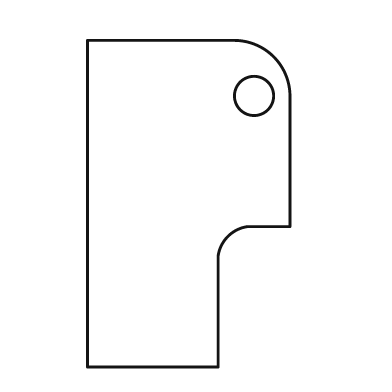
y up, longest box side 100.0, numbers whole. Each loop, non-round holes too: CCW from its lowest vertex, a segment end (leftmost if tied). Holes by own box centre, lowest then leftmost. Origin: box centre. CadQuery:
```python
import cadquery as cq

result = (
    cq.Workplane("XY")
    .moveTo(-31.0, -50.0)
    .lineTo(9.0, -50.0)
    .lineTo(9.0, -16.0)
    .threePointArc((12.0, -10.0), (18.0, -7.0))
    .lineTo(31.0, -7.0)
    .lineTo(31.0, 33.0)
    .threePointArc((26.0, 45.0), (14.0, 50.0))
    .lineTo(-31.0, 50.0)
    .close()
    .moveTo(20.0, 33.0)
    .circle(6.0)
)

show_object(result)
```